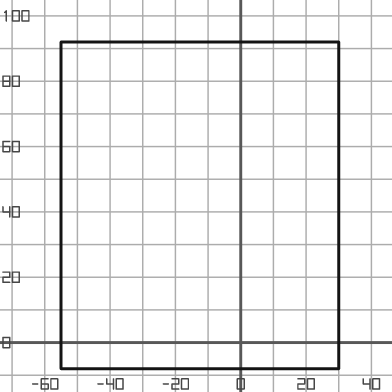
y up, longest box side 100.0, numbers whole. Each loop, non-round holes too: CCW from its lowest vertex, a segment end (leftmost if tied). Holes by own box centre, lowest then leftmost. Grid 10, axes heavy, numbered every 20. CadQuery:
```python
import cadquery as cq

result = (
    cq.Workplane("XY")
    .moveTo(-55.0, -8.0)
    .lineTo(30.0, -8.0)
    .lineTo(30.0, 92.0)
    .lineTo(-55.0, 92.0)
    .close()
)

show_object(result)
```